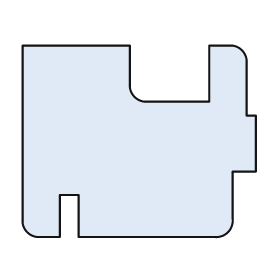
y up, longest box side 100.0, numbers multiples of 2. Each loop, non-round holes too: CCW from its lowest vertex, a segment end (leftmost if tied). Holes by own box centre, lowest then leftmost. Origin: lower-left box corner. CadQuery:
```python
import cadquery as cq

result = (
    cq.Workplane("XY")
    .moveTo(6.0, 0.0)
    .lineTo(16.0, 0.0)
    .lineTo(16.0, 18.0)
    .lineTo(24.0, 18.0)
    .lineTo(24.0, 0.0)
    .lineTo(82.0, 0.0)
    .threePointArc((88.0, 2.0), (90.0, 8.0))
    .lineTo(90.0, 28.0)
    .lineTo(100.0, 28.0)
    .lineTo(100.0, 52.0)
    .lineTo(96.0, 52.0)
    .lineTo(96.0, 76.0)
    .threePointArc((94.0, 80.0), (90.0, 82.0))
    .lineTo(80.0, 82.0)
    .lineTo(80.0, 58.0)
    .lineTo(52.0, 58.0)
    .threePointArc((48.0, 60.0), (46.0, 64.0))
    .lineTo(46.0, 82.0)
    .lineTo(0.0, 82.0)
    .lineTo(0.0, 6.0)
    .threePointArc((2.0, 2.0), (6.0, 0.0))
    .close()
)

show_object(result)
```